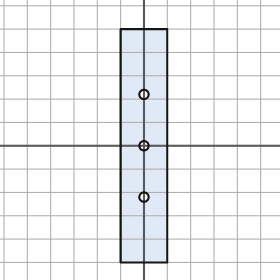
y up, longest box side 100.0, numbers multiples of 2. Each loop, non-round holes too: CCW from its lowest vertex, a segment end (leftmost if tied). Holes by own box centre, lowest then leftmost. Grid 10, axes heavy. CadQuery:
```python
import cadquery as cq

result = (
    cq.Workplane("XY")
    .moveTo(-10.0, -50.0)
    .lineTo(10.0, -50.0)
    .lineTo(10.0, 50.0)
    .lineTo(-10.0, 50.0)
    .close()
    .moveTo(0.0, -22.0)
    .circle(2.0)
    .moveTo(0.0, 0.0)
    .circle(2.0)
    .moveTo(0.0, 22.0)
    .circle(2.0)
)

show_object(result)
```